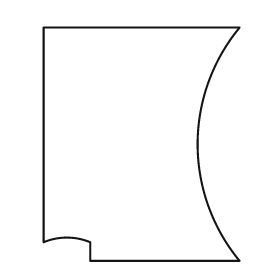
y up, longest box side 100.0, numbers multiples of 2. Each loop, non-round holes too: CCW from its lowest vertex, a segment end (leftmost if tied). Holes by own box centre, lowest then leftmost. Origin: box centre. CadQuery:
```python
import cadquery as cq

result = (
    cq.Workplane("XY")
    .moveTo(-22.0, -50.0)
    .lineTo(42.0, -50.0)
    .threePointArc((24.0, 0.0), (42.0, 50.0))
    .lineTo(-42.0, 50.0)
    .lineTo(-42.0, -42.0)
    .threePointArc((-32.0, -40.0), (-22.0, -42.0))
    .close()
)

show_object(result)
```